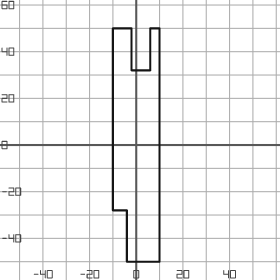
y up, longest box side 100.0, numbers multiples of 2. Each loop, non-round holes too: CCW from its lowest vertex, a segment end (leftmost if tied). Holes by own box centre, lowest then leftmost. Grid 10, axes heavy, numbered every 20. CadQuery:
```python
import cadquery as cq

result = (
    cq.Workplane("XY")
    .moveTo(-4.0, -50.0)
    .lineTo(10.0, -50.0)
    .lineTo(10.0, 50.0)
    .lineTo(6.0, 50.0)
    .lineTo(6.0, 32.0)
    .lineTo(-2.0, 32.0)
    .lineTo(-2.0, 50.0)
    .lineTo(-10.0, 50.0)
    .lineTo(-10.0, -28.0)
    .lineTo(-4.0, -28.0)
    .close()
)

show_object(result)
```